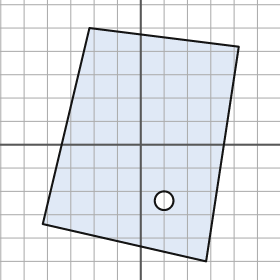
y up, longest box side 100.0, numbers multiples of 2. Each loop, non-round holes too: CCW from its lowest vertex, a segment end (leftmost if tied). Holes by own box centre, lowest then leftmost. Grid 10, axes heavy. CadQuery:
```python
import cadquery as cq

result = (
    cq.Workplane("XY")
    .moveTo(28.0, -50.0)
    .lineTo(42.0, 42.0)
    .lineTo(-22.0, 50.0)
    .lineTo(-42.0, -34.0)
    .close()
    .moveTo(10.0, -24.0)
    .circle(4.0)
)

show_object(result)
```